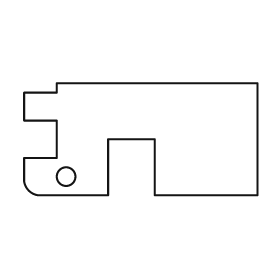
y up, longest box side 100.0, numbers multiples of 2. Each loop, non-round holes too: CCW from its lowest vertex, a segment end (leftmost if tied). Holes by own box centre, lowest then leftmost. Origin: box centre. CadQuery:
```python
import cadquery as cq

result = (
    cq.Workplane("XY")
    .moveTo(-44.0, -24.0)
    .lineTo(-14.0, -24.0)
    .lineTo(-14.0, 0.0)
    .lineTo(6.0, 0.0)
    .lineTo(6.0, -24.0)
    .lineTo(50.0, -24.0)
    .lineTo(50.0, 24.0)
    .lineTo(-36.0, 24.0)
    .lineTo(-36.0, 20.0)
    .lineTo(-50.0, 20.0)
    .lineTo(-50.0, 8.0)
    .lineTo(-36.0, 8.0)
    .lineTo(-36.0, -8.0)
    .lineTo(-50.0, -8.0)
    .lineTo(-50.0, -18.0)
    .threePointArc((-48.0, -22.0), (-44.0, -24.0))
    .close()
    .moveTo(-32.0, -16.0)
    .circle(4.0)
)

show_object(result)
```